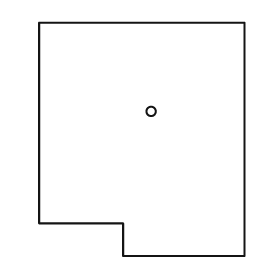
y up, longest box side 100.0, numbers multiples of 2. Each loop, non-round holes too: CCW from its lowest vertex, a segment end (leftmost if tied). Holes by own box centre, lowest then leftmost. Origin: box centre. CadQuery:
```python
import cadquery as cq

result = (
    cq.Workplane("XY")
    .moveTo(-8.0, -50.0)
    .lineTo(44.0, -50.0)
    .lineTo(44.0, 50.0)
    .lineTo(-44.0, 50.0)
    .lineTo(-44.0, -36.0)
    .lineTo(-8.0, -36.0)
    .close()
    .moveTo(4.0, 12.0)
    .circle(2.0)
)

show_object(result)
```